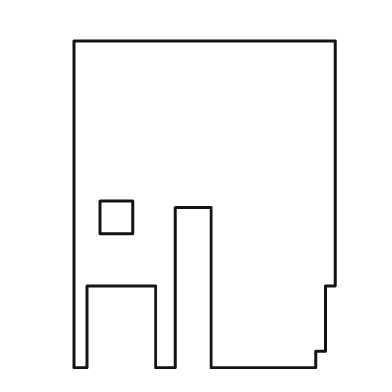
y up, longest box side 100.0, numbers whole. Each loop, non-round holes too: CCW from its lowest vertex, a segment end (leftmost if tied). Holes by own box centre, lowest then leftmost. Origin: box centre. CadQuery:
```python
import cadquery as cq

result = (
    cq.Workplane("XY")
    .moveTo(-40.0, -50.0)
    .lineTo(-36.0, -50.0)
    .lineTo(-36.0, -25.0)
    .lineTo(-15.0, -25.0)
    .lineTo(-15.0, -50.0)
    .lineTo(-9.0, -50.0)
    .lineTo(-9.0, -1.0)
    .lineTo(2.0, -1.0)
    .lineTo(2.0, -50.0)
    .lineTo(34.0, -50.0)
    .lineTo(34.0, -45.0)
    .lineTo(37.0, -45.0)
    .lineTo(37.0, -25.0)
    .lineTo(40.0, -25.0)
    .lineTo(40.0, 50.0)
    .lineTo(-40.0, 50.0)
    .close()
    .moveTo(-32.0, -9.0)
    .lineTo(-22.0, -9.0)
    .lineTo(-22.0, 1.0)
    .lineTo(-32.0, 1.0)
    .close()
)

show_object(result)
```